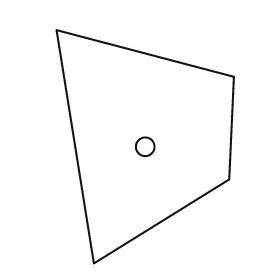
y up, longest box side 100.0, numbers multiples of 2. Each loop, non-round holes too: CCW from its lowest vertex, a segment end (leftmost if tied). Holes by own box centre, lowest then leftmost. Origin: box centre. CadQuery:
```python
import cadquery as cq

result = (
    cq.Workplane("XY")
    .moveTo(-22.0, -50.0)
    .lineTo(36.0, -14.0)
    .lineTo(38.0, 30.0)
    .lineTo(-38.0, 50.0)
    .close()
    .moveTo(0.0, 0.0)
    .circle(4.0)
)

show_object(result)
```